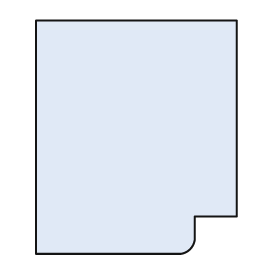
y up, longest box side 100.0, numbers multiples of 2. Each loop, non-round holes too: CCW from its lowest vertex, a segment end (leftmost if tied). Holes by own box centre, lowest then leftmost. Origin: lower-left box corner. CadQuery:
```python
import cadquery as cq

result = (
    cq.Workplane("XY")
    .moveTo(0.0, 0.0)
    .lineTo(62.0, 0.0)
    .threePointArc((66.0, 2.0), (68.0, 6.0))
    .lineTo(68.0, 16.0)
    .lineTo(86.0, 16.0)
    .lineTo(86.0, 100.0)
    .lineTo(0.0, 100.0)
    .close()
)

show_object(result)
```